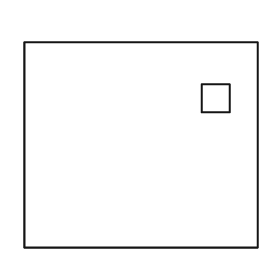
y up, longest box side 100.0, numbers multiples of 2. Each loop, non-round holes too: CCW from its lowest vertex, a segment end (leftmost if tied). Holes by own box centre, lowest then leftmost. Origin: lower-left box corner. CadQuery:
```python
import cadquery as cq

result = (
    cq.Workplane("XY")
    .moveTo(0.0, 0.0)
    .lineTo(100.0, 0.0)
    .lineTo(100.0, 88.0)
    .lineTo(0.0, 88.0)
    .close()
    .moveTo(76.0, 58.0)
    .lineTo(88.0, 58.0)
    .lineTo(88.0, 70.0)
    .lineTo(76.0, 70.0)
    .close()
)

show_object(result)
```